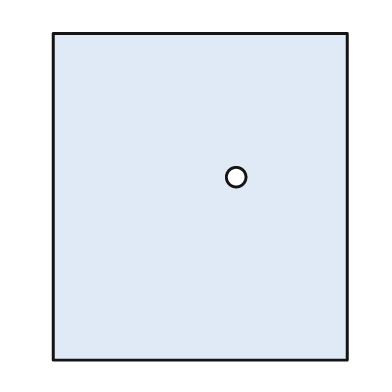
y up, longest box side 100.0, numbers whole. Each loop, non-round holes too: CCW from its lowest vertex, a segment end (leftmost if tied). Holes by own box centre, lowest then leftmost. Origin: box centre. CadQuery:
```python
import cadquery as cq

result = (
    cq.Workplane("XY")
    .moveTo(-45.0, -50.0)
    .lineTo(45.0, -50.0)
    .lineTo(45.0, 50.0)
    .lineTo(-45.0, 50.0)
    .close()
    .moveTo(11.0, 6.0)
    .circle(3.0)
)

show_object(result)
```